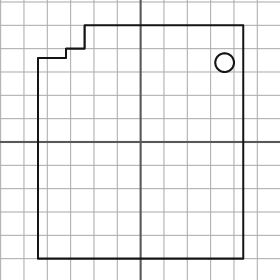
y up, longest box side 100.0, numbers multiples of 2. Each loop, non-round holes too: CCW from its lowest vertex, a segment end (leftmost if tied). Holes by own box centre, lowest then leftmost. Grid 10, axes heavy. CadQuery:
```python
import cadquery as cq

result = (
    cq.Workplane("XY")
    .moveTo(-44.0, -50.0)
    .lineTo(44.0, -50.0)
    .lineTo(44.0, 50.0)
    .lineTo(-24.0, 50.0)
    .lineTo(-24.0, 40.0)
    .lineTo(-32.0, 40.0)
    .lineTo(-32.0, 36.0)
    .lineTo(-44.0, 36.0)
    .close()
    .moveTo(36.0, 34.0)
    .circle(4.0)
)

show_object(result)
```